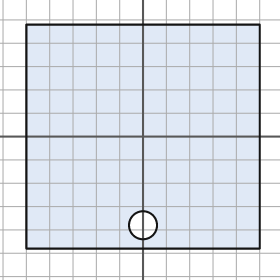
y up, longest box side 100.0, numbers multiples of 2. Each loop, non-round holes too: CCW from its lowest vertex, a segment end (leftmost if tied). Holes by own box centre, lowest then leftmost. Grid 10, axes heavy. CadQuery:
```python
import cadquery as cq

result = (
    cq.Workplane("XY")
    .moveTo(-50.0, -48.0)
    .lineTo(50.0, -48.0)
    .lineTo(50.0, 48.0)
    .lineTo(-50.0, 48.0)
    .close()
    .moveTo(0.0, -38.0)
    .circle(6.0)
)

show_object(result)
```